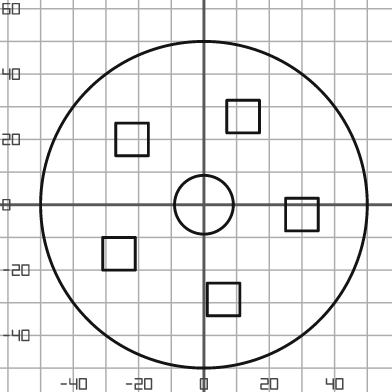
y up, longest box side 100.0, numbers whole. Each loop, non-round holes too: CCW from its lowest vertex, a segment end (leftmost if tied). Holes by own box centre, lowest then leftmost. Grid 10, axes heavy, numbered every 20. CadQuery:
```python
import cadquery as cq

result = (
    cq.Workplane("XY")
    .moveTo(0.0, 0.0)
    .circle(50.0)
    .moveTo(1.0, -34.0)
    .lineTo(11.0, -34.0)
    .lineTo(11.0, -24.0)
    .lineTo(1.0, -24.0)
    .close()
    .moveTo(-31.0, -20.0)
    .lineTo(-21.0, -20.0)
    .lineTo(-21.0, -10.0)
    .lineTo(-31.0, -10.0)
    .close()
    .moveTo(25.0, -8.0)
    .lineTo(35.0, -8.0)
    .lineTo(35.0, 2.0)
    .lineTo(25.0, 2.0)
    .close()
    .moveTo(0.0, 0.0)
    .circle(9.0)
    .moveTo(-27.0, 15.0)
    .lineTo(-17.0, 15.0)
    .lineTo(-17.0, 25.0)
    .lineTo(-27.0, 25.0)
    .close()
    .moveTo(7.0, 22.0)
    .lineTo(17.0, 22.0)
    .lineTo(17.0, 32.0)
    .lineTo(7.0, 32.0)
    .close()
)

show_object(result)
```